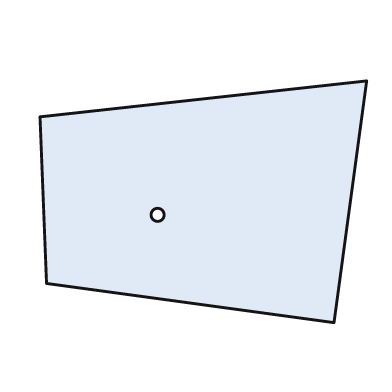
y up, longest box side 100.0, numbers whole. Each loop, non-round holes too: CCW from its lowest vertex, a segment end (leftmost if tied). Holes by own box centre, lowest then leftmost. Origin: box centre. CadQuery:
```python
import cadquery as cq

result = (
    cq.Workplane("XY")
    .moveTo(40.0, -37.0)
    .lineTo(50.0, 37.0)
    .lineTo(-50.0, 26.0)
    .lineTo(-48.0, -25.0)
    .close()
    .moveTo(-14.0, -4.0)
    .circle(2.0)
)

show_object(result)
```